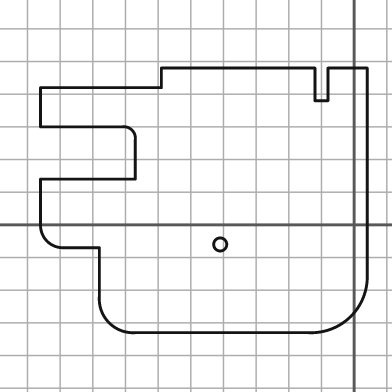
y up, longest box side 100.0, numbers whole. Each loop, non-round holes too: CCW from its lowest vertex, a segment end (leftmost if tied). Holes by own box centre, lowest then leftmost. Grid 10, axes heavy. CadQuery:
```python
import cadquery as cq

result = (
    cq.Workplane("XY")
    .moveTo(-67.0, -33.0)
    .lineTo(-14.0, -33.0)
    .threePointArc((-1.0, -28.0), (4.0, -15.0))
    .lineTo(4.0, 48.0)
    .lineTo(-8.0, 48.0)
    .lineTo(-8.0, 38.0)
    .lineTo(-12.0, 38.0)
    .lineTo(-12.0, 48.0)
    .lineTo(-59.0, 48.0)
    .lineTo(-59.0, 42.0)
    .lineTo(-96.0, 42.0)
    .lineTo(-96.0, 30.0)
    .lineTo(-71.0, 30.0)
    .threePointArc((-68.0, 29.0), (-67.0, 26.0))
    .lineTo(-67.0, 14.0)
    .lineTo(-96.0, 14.0)
    .lineTo(-96.0, 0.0)
    .threePointArc((-94.0, -5.0), (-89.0, -7.0))
    .lineTo(-78.0, -7.0)
    .lineTo(-78.0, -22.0)
    .threePointArc((-75.0, -30.0), (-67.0, -33.0))
    .close()
    .moveTo(-41.0, -6.0)
    .circle(2.0)
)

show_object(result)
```